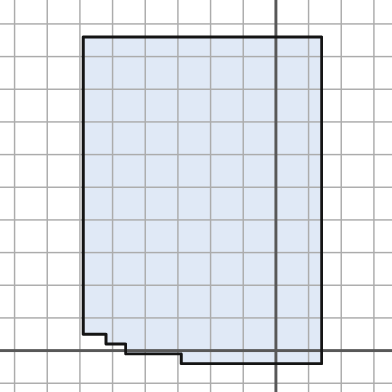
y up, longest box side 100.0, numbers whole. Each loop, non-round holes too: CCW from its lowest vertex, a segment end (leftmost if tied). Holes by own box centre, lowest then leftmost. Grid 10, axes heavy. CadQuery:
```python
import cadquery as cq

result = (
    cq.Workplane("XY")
    .moveTo(-29.0, -4.0)
    .lineTo(14.0, -4.0)
    .lineTo(14.0, 96.0)
    .lineTo(-59.0, 96.0)
    .lineTo(-59.0, 5.0)
    .lineTo(-52.0, 5.0)
    .lineTo(-52.0, 2.0)
    .lineTo(-46.0, 2.0)
    .lineTo(-46.0, -1.0)
    .lineTo(-29.0, -1.0)
    .close()
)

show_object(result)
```